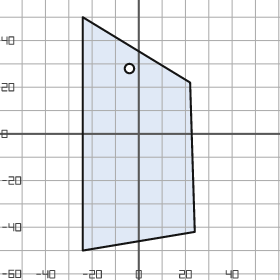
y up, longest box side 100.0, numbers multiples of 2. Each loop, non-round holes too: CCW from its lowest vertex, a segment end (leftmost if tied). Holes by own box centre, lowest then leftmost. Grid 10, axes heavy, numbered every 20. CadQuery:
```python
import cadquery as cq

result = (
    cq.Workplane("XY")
    .moveTo(-24.0, -50.0)
    .lineTo(24.0, -42.0)
    .lineTo(22.0, 22.0)
    .lineTo(-24.0, 50.0)
    .close()
    .moveTo(-4.0, 28.0)
    .circle(2.0)
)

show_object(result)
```